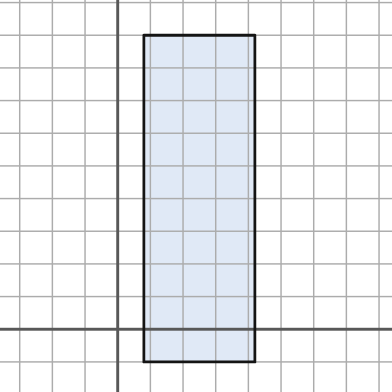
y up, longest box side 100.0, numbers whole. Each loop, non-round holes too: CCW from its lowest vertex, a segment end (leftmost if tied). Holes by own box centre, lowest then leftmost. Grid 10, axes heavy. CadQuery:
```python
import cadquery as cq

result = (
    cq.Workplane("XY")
    .moveTo(8.0, -10.0)
    .lineTo(42.0, -10.0)
    .lineTo(42.0, 90.0)
    .lineTo(8.0, 90.0)
    .close()
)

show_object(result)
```